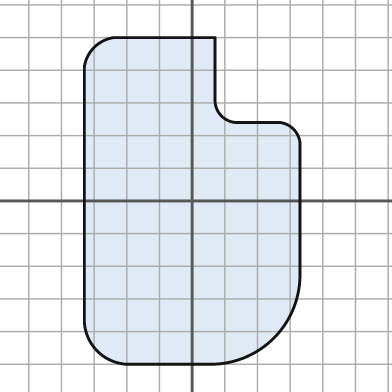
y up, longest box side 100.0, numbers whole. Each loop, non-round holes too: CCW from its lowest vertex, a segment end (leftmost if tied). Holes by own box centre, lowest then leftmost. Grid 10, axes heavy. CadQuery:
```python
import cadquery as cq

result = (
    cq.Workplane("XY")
    .moveTo(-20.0, -50.0)
    .lineTo(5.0, -50.0)
    .threePointArc((25.0, -42.0), (33.0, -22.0))
    .lineTo(33.0, 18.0)
    .threePointArc((31.0, 22.0), (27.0, 24.0))
    .lineTo(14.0, 24.0)
    .threePointArc((9.0, 26.0), (7.0, 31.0))
    .lineTo(7.0, 50.0)
    .lineTo(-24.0, 50.0)
    .threePointArc((-30.0, 47.0), (-33.0, 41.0))
    .lineTo(-33.0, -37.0)
    .threePointArc((-29.0, -46.0), (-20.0, -50.0))
    .close()
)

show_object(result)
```